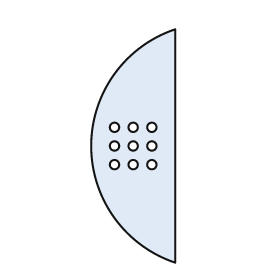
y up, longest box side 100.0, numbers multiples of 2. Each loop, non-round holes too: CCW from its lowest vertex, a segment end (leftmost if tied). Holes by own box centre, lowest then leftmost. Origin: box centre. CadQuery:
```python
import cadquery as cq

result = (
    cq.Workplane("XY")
    .moveTo(18.0, -50.0)
    .lineTo(18.0, 50.0)
    .threePointArc((-18.0, 0.0), (18.0, -50.0))
    .close()
    .moveTo(-8.0, -8.0)
    .circle(2.0)
    .moveTo(0.0, -8.0)
    .circle(2.0)
    .moveTo(8.0, -8.0)
    .circle(2.0)
    .moveTo(-8.0, 0.0)
    .circle(2.0)
    .moveTo(0.0, 0.0)
    .circle(2.0)
    .moveTo(8.0, 0.0)
    .circle(2.0)
    .moveTo(-8.0, 8.0)
    .circle(2.0)
    .moveTo(0.0, 8.0)
    .circle(2.0)
    .moveTo(8.0, 8.0)
    .circle(2.0)
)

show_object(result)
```